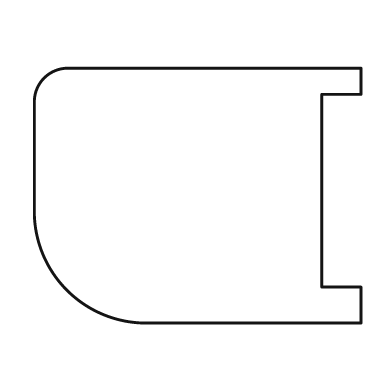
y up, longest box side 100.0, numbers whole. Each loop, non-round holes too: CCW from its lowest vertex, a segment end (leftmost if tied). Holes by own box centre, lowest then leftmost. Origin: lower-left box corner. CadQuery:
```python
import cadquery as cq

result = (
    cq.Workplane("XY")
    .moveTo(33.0, 0.0)
    .lineTo(100.0, 0.0)
    .lineTo(100.0, 11.0)
    .lineTo(88.0, 11.0)
    .lineTo(88.0, 70.0)
    .lineTo(100.0, 70.0)
    .lineTo(100.0, 78.0)
    .lineTo(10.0, 78.0)
    .threePointArc((3.0, 75.0), (0.0, 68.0))
    .lineTo(0.0, 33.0)
    .threePointArc((10.0, 10.0), (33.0, 0.0))
    .close()
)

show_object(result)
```